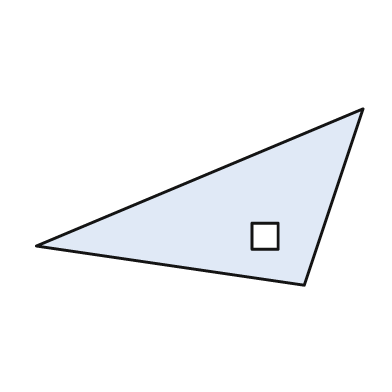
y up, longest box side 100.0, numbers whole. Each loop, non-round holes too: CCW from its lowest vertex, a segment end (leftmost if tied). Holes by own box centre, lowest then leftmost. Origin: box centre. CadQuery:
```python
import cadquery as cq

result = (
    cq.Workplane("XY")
    .moveTo(32.0, -27.0)
    .lineTo(50.0, 27.0)
    .lineTo(-50.0, -15.0)
    .close()
    .moveTo(16.0, -16.0)
    .lineTo(24.0, -16.0)
    .lineTo(24.0, -8.0)
    .lineTo(16.0, -8.0)
    .close()
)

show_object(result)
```